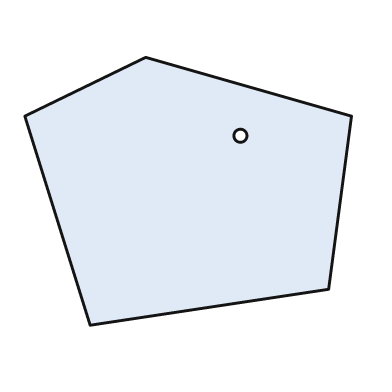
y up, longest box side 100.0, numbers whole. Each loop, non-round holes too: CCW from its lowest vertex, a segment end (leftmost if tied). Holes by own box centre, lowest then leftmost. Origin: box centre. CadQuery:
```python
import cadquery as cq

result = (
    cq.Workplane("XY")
    .moveTo(-30.0, -41.0)
    .lineTo(43.0, -30.0)
    .lineTo(50.0, 23.0)
    .lineTo(-13.0, 41.0)
    .lineTo(-50.0, 23.0)
    .close()
    .moveTo(16.0, 17.0)
    .circle(2.0)
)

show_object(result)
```